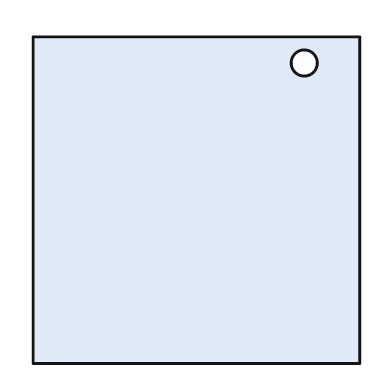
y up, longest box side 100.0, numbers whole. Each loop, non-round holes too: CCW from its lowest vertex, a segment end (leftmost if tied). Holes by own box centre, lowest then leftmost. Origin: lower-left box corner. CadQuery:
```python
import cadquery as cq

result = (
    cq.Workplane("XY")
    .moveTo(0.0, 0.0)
    .lineTo(100.0, 0.0)
    .lineTo(100.0, 100.0)
    .lineTo(0.0, 100.0)
    .close()
    .moveTo(83.0, 92.0)
    .circle(4.0)
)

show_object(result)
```